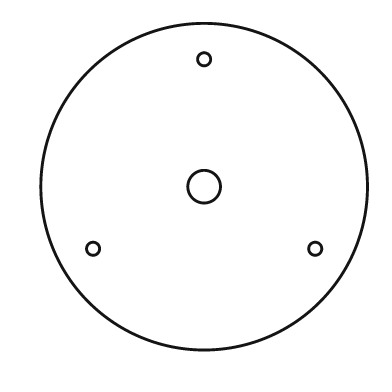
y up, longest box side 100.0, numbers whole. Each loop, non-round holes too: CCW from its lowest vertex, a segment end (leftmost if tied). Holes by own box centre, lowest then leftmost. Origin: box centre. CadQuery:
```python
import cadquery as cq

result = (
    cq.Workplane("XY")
    .moveTo(0.0, 0.0)
    .circle(50.0)
    .moveTo(-34.0, -19.0)
    .circle(2.0)
    .moveTo(34.0, -19.0)
    .circle(2.0)
    .moveTo(0.0, 0.0)
    .circle(5.0)
    .moveTo(0.0, 39.0)
    .circle(2.0)
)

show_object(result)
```